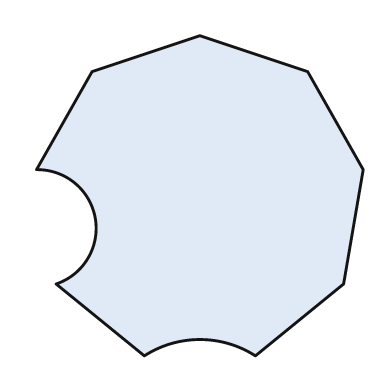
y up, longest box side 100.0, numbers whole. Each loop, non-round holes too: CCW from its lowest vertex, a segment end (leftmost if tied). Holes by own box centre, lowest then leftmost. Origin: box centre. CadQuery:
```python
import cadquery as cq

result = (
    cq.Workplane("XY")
    .moveTo(-17.0, -49.0)
    .threePointArc((0.0, -44.0), (17.0, -49.0))
    .lineTo(44.0, -27.0)
    .lineTo(50.0, 8.0)
    .lineTo(33.0, 38.0)
    .lineTo(0.0, 49.0)
    .lineTo(-33.0, 38.0)
    .lineTo(-50.0, 8.0)
    .threePointArc((-32.0, -7.0), (-44.0, -27.0))
    .close()
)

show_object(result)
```